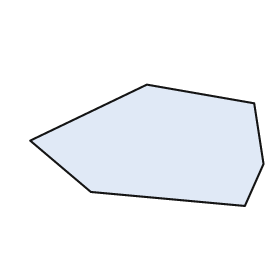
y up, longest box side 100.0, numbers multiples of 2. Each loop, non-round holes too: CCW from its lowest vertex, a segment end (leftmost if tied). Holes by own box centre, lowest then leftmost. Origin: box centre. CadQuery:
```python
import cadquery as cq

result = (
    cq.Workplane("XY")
    .moveTo(42.0, -26.0)
    .lineTo(50.0, -8.0)
    .lineTo(46.0, 18.0)
    .lineTo(0.0, 26.0)
    .lineTo(-50.0, 2.0)
    .lineTo(-24.0, -20.0)
    .close()
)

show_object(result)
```